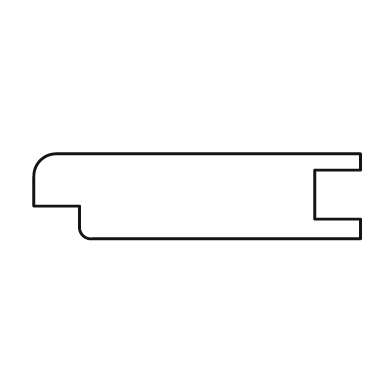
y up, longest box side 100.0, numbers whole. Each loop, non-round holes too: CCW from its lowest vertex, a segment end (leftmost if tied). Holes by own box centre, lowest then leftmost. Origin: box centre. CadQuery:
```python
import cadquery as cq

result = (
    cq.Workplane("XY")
    .moveTo(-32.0, -13.0)
    .lineTo(50.0, -13.0)
    .lineTo(50.0, -7.0)
    .lineTo(36.0, -7.0)
    .lineTo(36.0, 8.0)
    .lineTo(50.0, 8.0)
    .lineTo(50.0, 13.0)
    .lineTo(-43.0, 13.0)
    .threePointArc((-48.0, 11.0), (-50.0, 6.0))
    .lineTo(-50.0, -3.0)
    .lineTo(-36.0, -3.0)
    .lineTo(-36.0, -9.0)
    .threePointArc((-35.0, -12.0), (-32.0, -13.0))
    .close()
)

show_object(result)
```